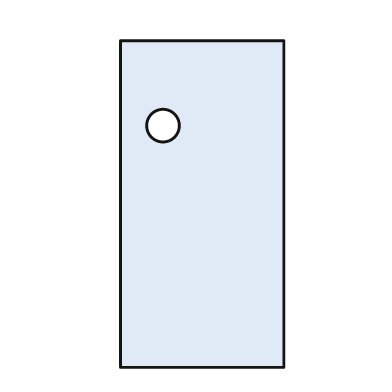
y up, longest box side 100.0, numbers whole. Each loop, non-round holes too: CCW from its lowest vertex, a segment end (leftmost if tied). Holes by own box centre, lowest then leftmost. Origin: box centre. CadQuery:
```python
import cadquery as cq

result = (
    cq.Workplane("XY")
    .moveTo(-25.0, -50.0)
    .lineTo(25.0, -50.0)
    .lineTo(25.0, 50.0)
    .lineTo(-25.0, 50.0)
    .close()
    .moveTo(-12.0, 24.0)
    .circle(5.0)
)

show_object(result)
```